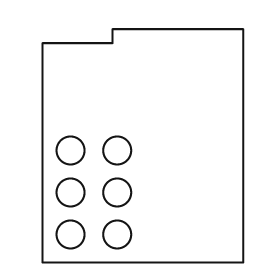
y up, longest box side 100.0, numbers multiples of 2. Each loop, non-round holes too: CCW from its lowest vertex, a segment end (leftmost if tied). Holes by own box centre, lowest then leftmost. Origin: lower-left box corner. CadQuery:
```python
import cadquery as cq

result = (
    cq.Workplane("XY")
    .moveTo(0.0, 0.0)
    .lineTo(86.0, 0.0)
    .lineTo(86.0, 100.0)
    .lineTo(30.0, 100.0)
    .lineTo(30.0, 94.0)
    .lineTo(0.0, 94.0)
    .close()
    .moveTo(12.0, 12.0)
    .circle(6.0)
    .moveTo(32.0, 12.0)
    .circle(6.0)
    .moveTo(12.0, 30.0)
    .circle(6.0)
    .moveTo(32.0, 30.0)
    .circle(6.0)
    .moveTo(12.0, 48.0)
    .circle(6.0)
    .moveTo(32.0, 48.0)
    .circle(6.0)
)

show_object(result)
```